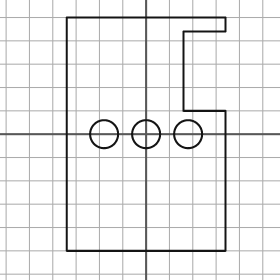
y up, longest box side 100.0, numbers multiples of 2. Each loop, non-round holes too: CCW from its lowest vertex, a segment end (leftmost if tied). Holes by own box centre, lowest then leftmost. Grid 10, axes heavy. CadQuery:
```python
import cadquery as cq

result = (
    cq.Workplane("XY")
    .moveTo(-34.0, -50.0)
    .lineTo(34.0, -50.0)
    .lineTo(34.0, 10.0)
    .lineTo(16.0, 10.0)
    .lineTo(16.0, 44.0)
    .lineTo(34.0, 44.0)
    .lineTo(34.0, 50.0)
    .lineTo(-34.0, 50.0)
    .close()
    .moveTo(-18.0, 0.0)
    .circle(6.0)
    .moveTo(0.0, 0.0)
    .circle(6.0)
    .moveTo(18.0, 0.0)
    .circle(6.0)
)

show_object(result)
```